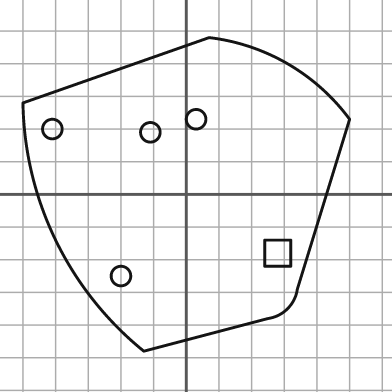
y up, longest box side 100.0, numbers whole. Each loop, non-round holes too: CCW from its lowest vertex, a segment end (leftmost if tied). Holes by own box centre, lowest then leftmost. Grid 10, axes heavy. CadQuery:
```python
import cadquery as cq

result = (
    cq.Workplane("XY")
    .moveTo(-13.0, -48.0)
    .lineTo(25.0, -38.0)
    .threePointArc((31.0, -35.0), (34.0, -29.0))
    .lineTo(50.0, 23.0)
    .threePointArc((31.0, 40.0), (7.0, 48.0))
    .lineTo(-50.0, 28.0)
    .threePointArc((-40.0, -14.0), (-13.0, -48.0))
    .close()
    .moveTo(-20.0, -25.0)
    .circle(3.0)
    .moveTo(24.0, -22.0)
    .lineTo(32.0, -22.0)
    .lineTo(32.0, -14.0)
    .lineTo(24.0, -14.0)
    .close()
    .moveTo(-11.0, 19.0)
    .circle(3.0)
    .moveTo(-41.0, 20.0)
    .circle(3.0)
    .moveTo(3.0, 23.0)
    .circle(3.0)
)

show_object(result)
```